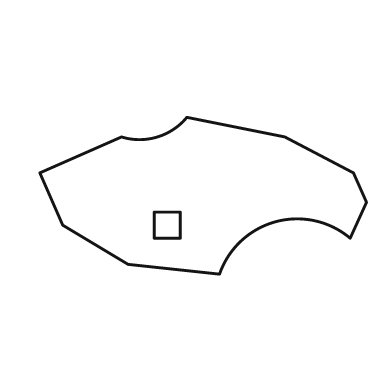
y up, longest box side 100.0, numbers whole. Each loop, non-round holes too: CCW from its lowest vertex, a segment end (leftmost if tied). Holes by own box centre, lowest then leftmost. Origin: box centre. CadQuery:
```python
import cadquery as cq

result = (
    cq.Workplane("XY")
    .moveTo(5.0, -24.0)
    .threePointArc((22.0, -8.0), (45.0, -13.0))
    .lineTo(50.0, -2.0)
    .lineTo(46.0, 7.0)
    .lineTo(25.0, 18.0)
    .lineTo(-5.0, 24.0)
    .threePointArc((-14.0, 18.0), (-25.0, 18.0))
    .lineTo(-50.0, 7.0)
    .lineTo(-43.0, -9.0)
    .lineTo(-23.0, -21.0)
    .close()
    .moveTo(-15.0, -13.0)
    .lineTo(-7.0, -13.0)
    .lineTo(-7.0, -5.0)
    .lineTo(-15.0, -5.0)
    .close()
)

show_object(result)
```